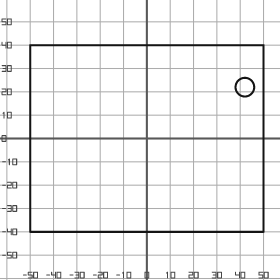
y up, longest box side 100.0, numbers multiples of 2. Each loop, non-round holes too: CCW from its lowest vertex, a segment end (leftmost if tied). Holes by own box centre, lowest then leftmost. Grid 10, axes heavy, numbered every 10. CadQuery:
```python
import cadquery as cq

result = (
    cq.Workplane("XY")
    .moveTo(-50.0, -40.0)
    .lineTo(50.0, -40.0)
    .lineTo(50.0, 40.0)
    .lineTo(-50.0, 40.0)
    .close()
    .moveTo(42.0, 22.0)
    .circle(4.0)
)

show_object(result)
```